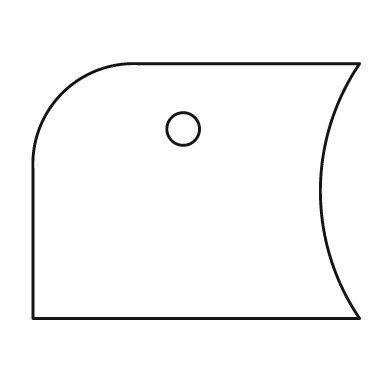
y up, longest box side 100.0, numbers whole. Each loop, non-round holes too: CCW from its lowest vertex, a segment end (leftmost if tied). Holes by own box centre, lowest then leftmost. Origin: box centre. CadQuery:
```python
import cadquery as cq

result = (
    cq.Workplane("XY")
    .moveTo(-50.0, -39.0)
    .lineTo(50.0, -39.0)
    .threePointArc((38.0, 0.0), (50.0, 39.0))
    .lineTo(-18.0, 39.0)
    .threePointArc((-41.0, 30.0), (-50.0, 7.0))
    .close()
    .moveTo(-4.0, 19.0)
    .circle(5.0)
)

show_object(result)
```